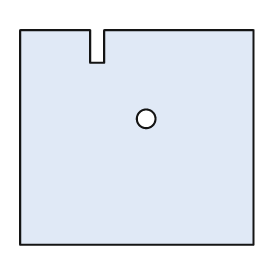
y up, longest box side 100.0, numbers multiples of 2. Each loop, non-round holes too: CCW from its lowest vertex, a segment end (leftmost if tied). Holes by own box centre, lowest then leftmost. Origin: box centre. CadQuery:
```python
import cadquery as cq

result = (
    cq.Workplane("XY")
    .moveTo(-50.0, -46.0)
    .lineTo(50.0, -46.0)
    .lineTo(50.0, 46.0)
    .lineTo(-14.0, 46.0)
    .lineTo(-14.0, 32.0)
    .lineTo(-20.0, 32.0)
    .lineTo(-20.0, 46.0)
    .lineTo(-50.0, 46.0)
    .close()
    .moveTo(4.0, 8.0)
    .circle(4.0)
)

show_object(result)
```